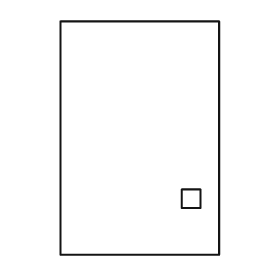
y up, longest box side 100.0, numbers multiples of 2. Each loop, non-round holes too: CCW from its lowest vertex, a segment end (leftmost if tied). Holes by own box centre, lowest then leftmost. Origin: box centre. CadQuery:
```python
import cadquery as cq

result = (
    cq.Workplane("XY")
    .moveTo(-34.0, -50.0)
    .lineTo(34.0, -50.0)
    .lineTo(34.0, 50.0)
    .lineTo(-34.0, 50.0)
    .close()
    .moveTo(18.0, -30.0)
    .lineTo(26.0, -30.0)
    .lineTo(26.0, -22.0)
    .lineTo(18.0, -22.0)
    .close()
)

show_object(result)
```